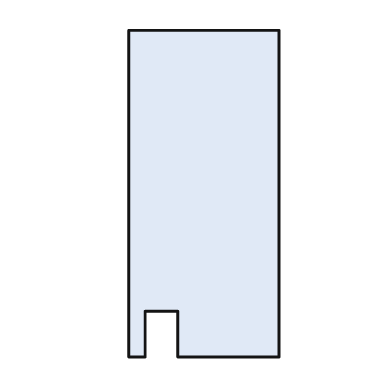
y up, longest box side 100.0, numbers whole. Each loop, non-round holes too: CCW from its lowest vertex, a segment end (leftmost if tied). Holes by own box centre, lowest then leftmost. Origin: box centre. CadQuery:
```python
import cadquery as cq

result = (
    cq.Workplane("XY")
    .moveTo(-23.0, -50.0)
    .lineTo(-18.0, -50.0)
    .lineTo(-18.0, -36.0)
    .lineTo(-8.0, -36.0)
    .lineTo(-8.0, -50.0)
    .lineTo(23.0, -50.0)
    .lineTo(23.0, 50.0)
    .lineTo(-23.0, 50.0)
    .close()
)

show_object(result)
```